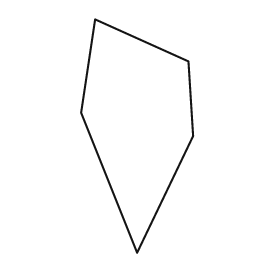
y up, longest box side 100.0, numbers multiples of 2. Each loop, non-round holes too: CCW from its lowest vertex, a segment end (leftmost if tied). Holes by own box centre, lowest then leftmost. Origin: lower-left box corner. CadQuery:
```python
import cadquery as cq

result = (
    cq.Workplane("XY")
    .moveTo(24.0, 0.0)
    .lineTo(48.0, 50.0)
    .lineTo(46.0, 82.0)
    .lineTo(6.0, 100.0)
    .lineTo(0.0, 60.0)
    .close()
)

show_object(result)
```